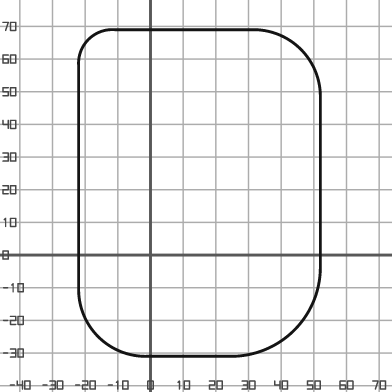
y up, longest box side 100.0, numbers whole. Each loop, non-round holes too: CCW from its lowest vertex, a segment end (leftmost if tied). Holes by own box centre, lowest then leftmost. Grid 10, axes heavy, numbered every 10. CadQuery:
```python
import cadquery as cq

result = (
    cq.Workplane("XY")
    .moveTo(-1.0, -31.0)
    .lineTo(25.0, -31.0)
    .threePointArc((44.0, -23.0), (52.0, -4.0))
    .lineTo(52.0, 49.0)
    .threePointArc((46.0, 63.0), (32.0, 69.0))
    .lineTo(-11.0, 69.0)
    .threePointArc((-19.0, 66.0), (-22.0, 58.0))
    .lineTo(-22.0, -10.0)
    .threePointArc((-16.0, -25.0), (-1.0, -31.0))
    .close()
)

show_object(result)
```